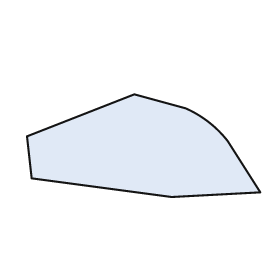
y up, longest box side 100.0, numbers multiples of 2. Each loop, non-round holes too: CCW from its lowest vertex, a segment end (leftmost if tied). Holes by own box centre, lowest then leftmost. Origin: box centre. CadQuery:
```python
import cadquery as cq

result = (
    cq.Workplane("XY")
    .moveTo(12.0, -22.0)
    .lineTo(50.0, -20.0)
    .lineTo(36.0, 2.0)
    .threePointArc((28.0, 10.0), (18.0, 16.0))
    .lineTo(-4.0, 22.0)
    .lineTo(-50.0, 4.0)
    .lineTo(-48.0, -14.0)
    .close()
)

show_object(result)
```